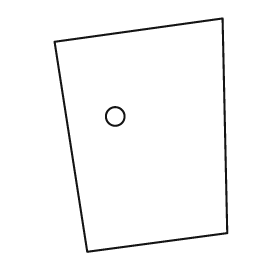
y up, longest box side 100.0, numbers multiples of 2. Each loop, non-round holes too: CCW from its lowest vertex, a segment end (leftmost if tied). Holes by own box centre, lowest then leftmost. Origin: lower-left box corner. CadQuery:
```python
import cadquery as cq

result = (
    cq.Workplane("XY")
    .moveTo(14.0, 0.0)
    .lineTo(74.0, 8.0)
    .lineTo(72.0, 100.0)
    .lineTo(0.0, 90.0)
    .close()
    .moveTo(26.0, 58.0)
    .circle(4.0)
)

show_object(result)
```